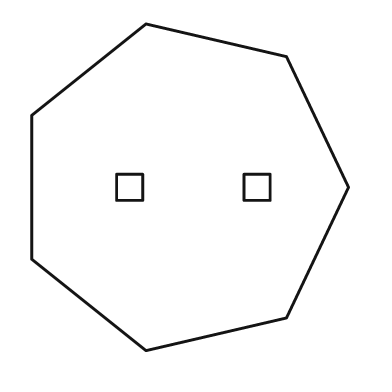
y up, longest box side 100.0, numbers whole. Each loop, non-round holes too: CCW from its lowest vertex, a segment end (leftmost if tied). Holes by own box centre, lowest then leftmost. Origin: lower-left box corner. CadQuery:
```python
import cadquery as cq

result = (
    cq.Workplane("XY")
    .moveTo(35.0, 0.0)
    .lineTo(78.0, 10.0)
    .lineTo(97.0, 50.0)
    .lineTo(78.0, 90.0)
    .lineTo(35.0, 100.0)
    .lineTo(0.0, 72.0)
    .lineTo(0.0, 28.0)
    .close()
    .moveTo(26.0, 46.0)
    .lineTo(34.0, 46.0)
    .lineTo(34.0, 54.0)
    .lineTo(26.0, 54.0)
    .close()
    .moveTo(65.0, 46.0)
    .lineTo(73.0, 46.0)
    .lineTo(73.0, 54.0)
    .lineTo(65.0, 54.0)
    .close()
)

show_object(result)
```